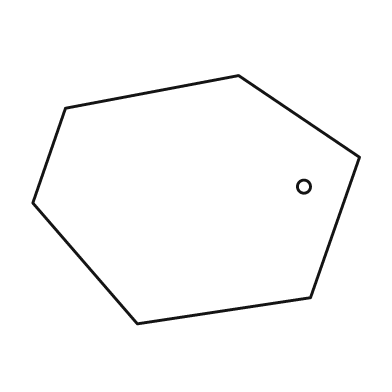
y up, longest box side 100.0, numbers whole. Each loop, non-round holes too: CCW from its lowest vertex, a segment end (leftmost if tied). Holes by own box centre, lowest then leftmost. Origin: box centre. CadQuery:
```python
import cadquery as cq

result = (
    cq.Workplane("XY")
    .moveTo(-18.0, -38.0)
    .lineTo(35.0, -30.0)
    .lineTo(50.0, 13.0)
    .lineTo(13.0, 38.0)
    .lineTo(-40.0, 28.0)
    .lineTo(-50.0, -1.0)
    .close()
    .moveTo(33.0, 4.0)
    .circle(2.0)
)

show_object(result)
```